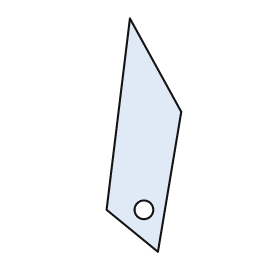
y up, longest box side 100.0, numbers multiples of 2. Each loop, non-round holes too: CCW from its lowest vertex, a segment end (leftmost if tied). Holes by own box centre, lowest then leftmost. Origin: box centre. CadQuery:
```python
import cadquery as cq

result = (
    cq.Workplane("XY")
    .moveTo(6.0, -50.0)
    .lineTo(16.0, 10.0)
    .lineTo(-6.0, 50.0)
    .lineTo(-16.0, -32.0)
    .close()
    .moveTo(0.0, -32.0)
    .circle(4.0)
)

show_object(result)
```